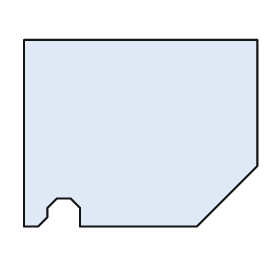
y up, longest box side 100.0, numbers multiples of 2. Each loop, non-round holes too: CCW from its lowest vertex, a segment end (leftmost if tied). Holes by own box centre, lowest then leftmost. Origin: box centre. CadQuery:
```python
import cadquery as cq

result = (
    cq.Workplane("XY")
    .moveTo(-50.0, -40.0)
    .lineTo(-44.0, -40.0)
    .lineTo(-40.0, -36.0)
    .lineTo(-40.0, -32.0)
    .lineTo(-36.0, -28.0)
    .lineTo(-30.0, -28.0)
    .lineTo(-26.0, -32.0)
    .lineTo(-26.0, -40.0)
    .lineTo(24.0, -40.0)
    .lineTo(50.0, -14.0)
    .lineTo(50.0, 40.0)
    .lineTo(-50.0, 40.0)
    .close()
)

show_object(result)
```